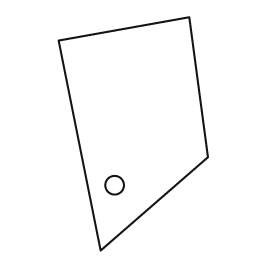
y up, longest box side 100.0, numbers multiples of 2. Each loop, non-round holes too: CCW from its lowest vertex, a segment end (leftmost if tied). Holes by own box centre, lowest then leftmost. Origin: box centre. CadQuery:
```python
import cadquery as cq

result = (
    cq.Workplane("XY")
    .moveTo(-14.0, -50.0)
    .lineTo(32.0, -10.0)
    .lineTo(24.0, 50.0)
    .lineTo(-32.0, 40.0)
    .close()
    .moveTo(-8.0, -22.0)
    .circle(4.0)
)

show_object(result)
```